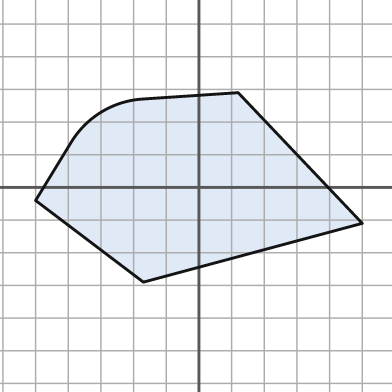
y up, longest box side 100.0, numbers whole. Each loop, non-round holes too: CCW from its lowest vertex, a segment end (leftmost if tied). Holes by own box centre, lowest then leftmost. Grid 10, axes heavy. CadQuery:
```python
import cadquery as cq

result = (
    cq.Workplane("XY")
    .moveTo(-17.0, -29.0)
    .lineTo(50.0, -11.0)
    .lineTo(12.0, 29.0)
    .lineTo(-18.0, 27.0)
    .threePointArc((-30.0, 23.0), (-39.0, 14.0))
    .lineTo(-50.0, -4.0)
    .close()
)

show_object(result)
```